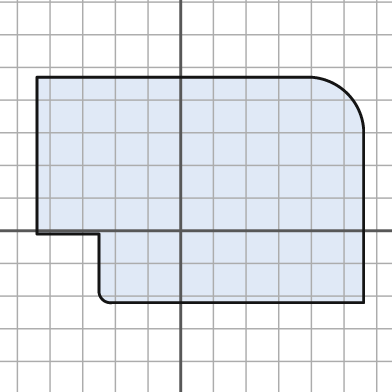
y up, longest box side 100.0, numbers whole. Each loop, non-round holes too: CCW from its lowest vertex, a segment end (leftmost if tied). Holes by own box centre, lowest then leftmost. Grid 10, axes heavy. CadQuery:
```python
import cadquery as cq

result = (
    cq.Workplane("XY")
    .moveTo(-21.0, -22.0)
    .lineTo(56.0, -22.0)
    .lineTo(56.0, 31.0)
    .threePointArc((51.0, 42.0), (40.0, 47.0))
    .lineTo(-44.0, 47.0)
    .lineTo(-44.0, -1.0)
    .lineTo(-25.0, -1.0)
    .lineTo(-25.0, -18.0)
    .threePointArc((-24.0, -21.0), (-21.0, -22.0))
    .close()
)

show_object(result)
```